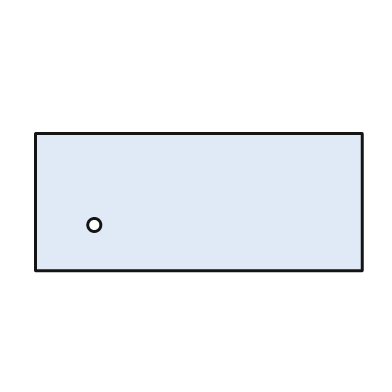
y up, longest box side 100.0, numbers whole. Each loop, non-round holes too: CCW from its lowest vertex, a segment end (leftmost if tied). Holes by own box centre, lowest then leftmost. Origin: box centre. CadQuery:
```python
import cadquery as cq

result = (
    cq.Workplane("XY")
    .moveTo(-50.0, -21.0)
    .lineTo(50.0, -21.0)
    .lineTo(50.0, 21.0)
    .lineTo(-50.0, 21.0)
    .close()
    .moveTo(-32.0, -7.0)
    .circle(2.0)
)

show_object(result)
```